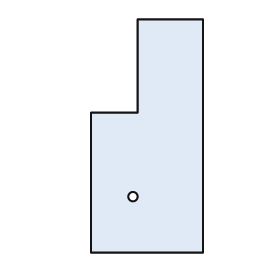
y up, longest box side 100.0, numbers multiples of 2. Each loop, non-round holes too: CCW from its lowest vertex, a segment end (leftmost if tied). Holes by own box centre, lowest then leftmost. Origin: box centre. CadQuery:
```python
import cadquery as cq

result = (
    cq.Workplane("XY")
    .moveTo(-24.0, -50.0)
    .lineTo(24.0, -50.0)
    .lineTo(24.0, 50.0)
    .lineTo(-4.0, 50.0)
    .lineTo(-4.0, 10.0)
    .lineTo(-24.0, 10.0)
    .close()
    .moveTo(-6.0, -26.0)
    .circle(2.0)
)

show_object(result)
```